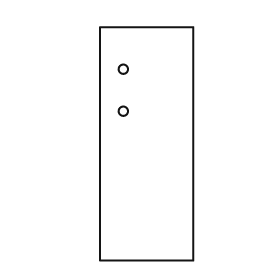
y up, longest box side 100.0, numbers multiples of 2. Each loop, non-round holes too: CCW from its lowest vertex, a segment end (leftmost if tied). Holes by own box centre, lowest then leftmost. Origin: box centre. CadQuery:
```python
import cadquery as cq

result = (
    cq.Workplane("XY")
    .moveTo(-20.0, -50.0)
    .lineTo(20.0, -50.0)
    .lineTo(20.0, 50.0)
    .lineTo(-20.0, 50.0)
    .close()
    .moveTo(-10.0, 14.0)
    .circle(2.0)
    .moveTo(-10.0, 32.0)
    .circle(2.0)
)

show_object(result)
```